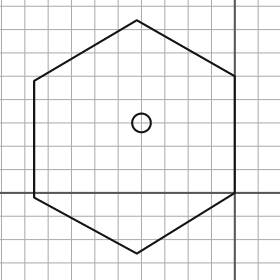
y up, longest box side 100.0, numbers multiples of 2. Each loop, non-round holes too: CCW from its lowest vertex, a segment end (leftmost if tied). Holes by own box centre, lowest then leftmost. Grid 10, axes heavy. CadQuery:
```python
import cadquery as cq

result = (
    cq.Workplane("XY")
    .moveTo(-42.0, -26.0)
    .lineTo(0.0, 0.0)
    .lineTo(0.0, 50.0)
    .lineTo(-42.0, 74.0)
    .lineTo(-86.0, 48.0)
    .lineTo(-86.0, -2.0)
    .close()
    .moveTo(-40.0, 30.0)
    .circle(4.0)
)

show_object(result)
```